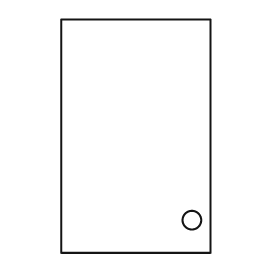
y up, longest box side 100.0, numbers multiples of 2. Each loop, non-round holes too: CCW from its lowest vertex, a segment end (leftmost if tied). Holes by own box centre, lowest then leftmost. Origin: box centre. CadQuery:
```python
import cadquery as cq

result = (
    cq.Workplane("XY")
    .moveTo(-32.0, -50.0)
    .lineTo(32.0, -50.0)
    .lineTo(32.0, 50.0)
    .lineTo(-32.0, 50.0)
    .close()
    .moveTo(24.0, -36.0)
    .circle(4.0)
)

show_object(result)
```